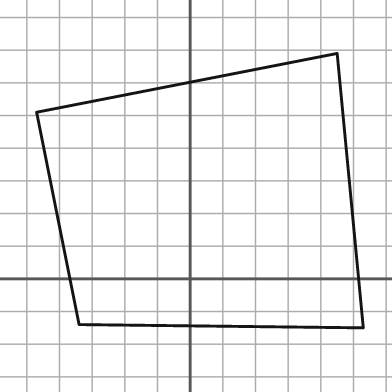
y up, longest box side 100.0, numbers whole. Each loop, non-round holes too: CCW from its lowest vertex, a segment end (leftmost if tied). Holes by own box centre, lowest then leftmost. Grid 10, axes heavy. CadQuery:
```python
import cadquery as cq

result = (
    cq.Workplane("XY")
    .moveTo(53.0, -15.0)
    .lineTo(45.0, 69.0)
    .lineTo(-47.0, 51.0)
    .lineTo(-34.0, -14.0)
    .close()
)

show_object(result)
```